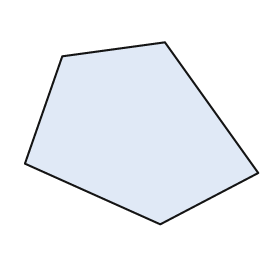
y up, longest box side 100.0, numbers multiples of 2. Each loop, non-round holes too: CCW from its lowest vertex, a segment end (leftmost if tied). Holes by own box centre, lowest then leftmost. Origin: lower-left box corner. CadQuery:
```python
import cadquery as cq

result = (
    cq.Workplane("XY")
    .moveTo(58.0, 0.0)
    .lineTo(100.0, 22.0)
    .lineTo(60.0, 78.0)
    .lineTo(16.0, 72.0)
    .lineTo(0.0, 26.0)
    .close()
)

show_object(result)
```